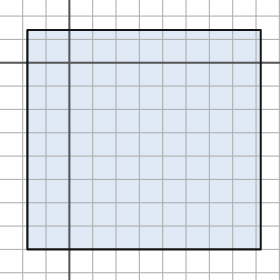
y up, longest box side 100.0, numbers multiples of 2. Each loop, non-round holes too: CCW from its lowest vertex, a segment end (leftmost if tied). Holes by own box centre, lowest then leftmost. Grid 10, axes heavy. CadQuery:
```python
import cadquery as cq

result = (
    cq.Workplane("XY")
    .moveTo(-18.0, -80.0)
    .lineTo(82.0, -80.0)
    .lineTo(82.0, 14.0)
    .lineTo(-18.0, 14.0)
    .close()
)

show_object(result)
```